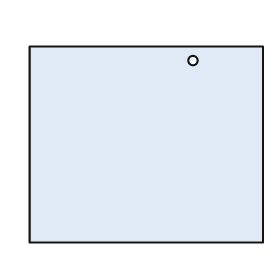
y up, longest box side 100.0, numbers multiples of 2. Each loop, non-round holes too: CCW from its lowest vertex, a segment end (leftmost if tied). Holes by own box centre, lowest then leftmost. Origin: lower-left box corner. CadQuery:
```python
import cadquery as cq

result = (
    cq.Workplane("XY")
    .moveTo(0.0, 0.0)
    .lineTo(100.0, 0.0)
    .lineTo(100.0, 84.0)
    .lineTo(0.0, 84.0)
    .close()
    .moveTo(70.0, 78.0)
    .circle(2.0)
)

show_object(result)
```